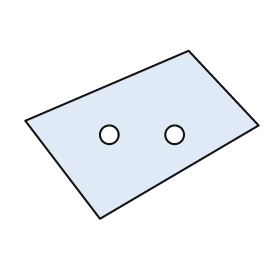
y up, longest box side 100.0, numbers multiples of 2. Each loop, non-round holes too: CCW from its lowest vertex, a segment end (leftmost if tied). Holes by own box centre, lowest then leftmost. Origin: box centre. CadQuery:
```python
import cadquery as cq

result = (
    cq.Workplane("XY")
    .moveTo(-18.0, -36.0)
    .lineTo(50.0, 4.0)
    .lineTo(20.0, 36.0)
    .lineTo(-50.0, 6.0)
    .close()
    .moveTo(-14.0, 0.0)
    .circle(4.0)
    .moveTo(14.0, 0.0)
    .circle(4.0)
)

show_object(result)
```